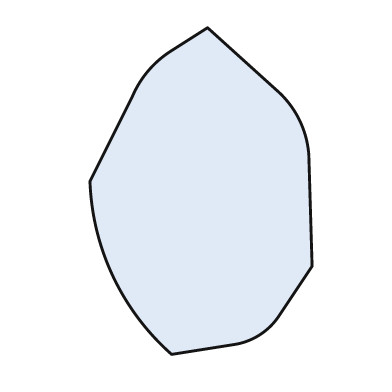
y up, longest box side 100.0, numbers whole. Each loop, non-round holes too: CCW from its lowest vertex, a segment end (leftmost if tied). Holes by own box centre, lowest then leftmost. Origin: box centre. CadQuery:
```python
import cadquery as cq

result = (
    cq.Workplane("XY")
    .moveTo(-9.0, -50.0)
    .lineTo(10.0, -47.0)
    .threePointArc((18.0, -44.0), (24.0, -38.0))
    .lineTo(34.0, -23.0)
    .lineTo(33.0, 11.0)
    .threePointArc((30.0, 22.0), (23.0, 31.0))
    .lineTo(2.0, 50.0)
    .lineTo(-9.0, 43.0)
    .threePointArc((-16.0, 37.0), (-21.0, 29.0))
    .lineTo(-34.0, 3.0)
    .threePointArc((-27.0, -26.0), (-9.0, -50.0))
    .close()
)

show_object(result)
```